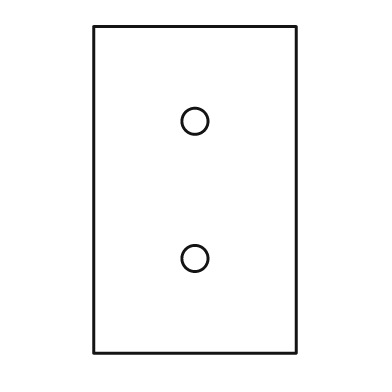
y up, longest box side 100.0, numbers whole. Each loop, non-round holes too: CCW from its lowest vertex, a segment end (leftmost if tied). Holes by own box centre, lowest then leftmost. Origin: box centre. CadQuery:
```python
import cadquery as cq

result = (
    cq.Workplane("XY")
    .moveTo(-31.0, -50.0)
    .lineTo(31.0, -50.0)
    .lineTo(31.0, 50.0)
    .lineTo(-31.0, 50.0)
    .close()
    .moveTo(0.0, -21.0)
    .circle(4.0)
    .moveTo(0.0, 21.0)
    .circle(4.0)
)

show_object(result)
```